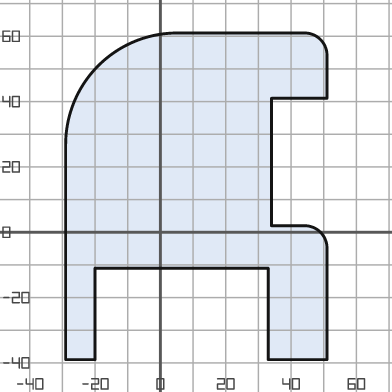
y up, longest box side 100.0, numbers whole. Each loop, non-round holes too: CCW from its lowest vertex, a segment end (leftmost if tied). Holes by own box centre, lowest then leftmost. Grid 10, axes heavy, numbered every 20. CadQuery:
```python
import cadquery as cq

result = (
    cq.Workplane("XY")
    .moveTo(-29.0, -39.0)
    .lineTo(-20.0, -39.0)
    .lineTo(-20.0, -11.0)
    .lineTo(33.0, -11.0)
    .lineTo(33.0, -39.0)
    .lineTo(51.0, -39.0)
    .lineTo(51.0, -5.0)
    .threePointArc((49.0, 0.0), (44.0, 2.0))
    .lineTo(34.0, 2.0)
    .lineTo(34.0, 41.0)
    .lineTo(51.0, 41.0)
    .lineTo(51.0, 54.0)
    .threePointArc((49.0, 59.0), (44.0, 61.0))
    .lineTo(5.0, 61.0)
    .threePointArc((-19.0, 51.0), (-29.0, 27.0))
    .close()
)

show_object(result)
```